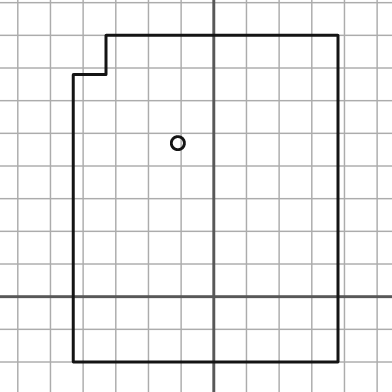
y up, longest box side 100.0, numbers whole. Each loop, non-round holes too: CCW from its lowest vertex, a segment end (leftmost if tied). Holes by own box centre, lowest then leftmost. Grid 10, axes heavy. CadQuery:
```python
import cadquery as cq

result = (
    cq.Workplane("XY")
    .moveTo(-43.0, -20.0)
    .lineTo(38.0, -20.0)
    .lineTo(38.0, 80.0)
    .lineTo(-33.0, 80.0)
    .lineTo(-33.0, 68.0)
    .lineTo(-43.0, 68.0)
    .close()
    .moveTo(-11.0, 47.0)
    .circle(2.0)
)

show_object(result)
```